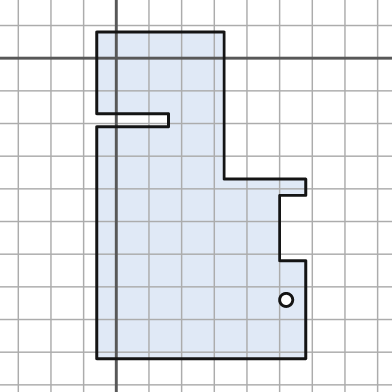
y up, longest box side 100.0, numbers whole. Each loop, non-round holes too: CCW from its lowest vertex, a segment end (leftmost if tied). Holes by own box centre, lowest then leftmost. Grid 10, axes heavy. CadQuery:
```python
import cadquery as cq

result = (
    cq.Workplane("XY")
    .moveTo(-6.0, -92.0)
    .lineTo(58.0, -92.0)
    .lineTo(58.0, -62.0)
    .lineTo(50.0, -62.0)
    .lineTo(50.0, -42.0)
    .lineTo(58.0, -42.0)
    .lineTo(58.0, -37.0)
    .lineTo(33.0, -37.0)
    .lineTo(33.0, 8.0)
    .lineTo(-6.0, 8.0)
    .lineTo(-6.0, -17.0)
    .lineTo(16.0, -17.0)
    .lineTo(16.0, -21.0)
    .lineTo(-6.0, -21.0)
    .close()
    .moveTo(52.0, -74.0)
    .circle(2.0)
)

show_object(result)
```